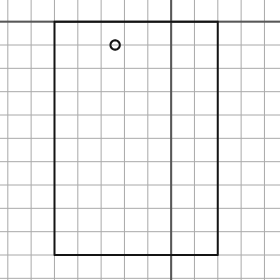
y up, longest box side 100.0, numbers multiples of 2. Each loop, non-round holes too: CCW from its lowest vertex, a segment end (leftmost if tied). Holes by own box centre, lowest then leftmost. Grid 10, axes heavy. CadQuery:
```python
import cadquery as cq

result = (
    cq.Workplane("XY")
    .moveTo(-50.0, -100.0)
    .lineTo(20.0, -100.0)
    .lineTo(20.0, 0.0)
    .lineTo(-50.0, 0.0)
    .close()
    .moveTo(-24.0, -10.0)
    .circle(2.0)
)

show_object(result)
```